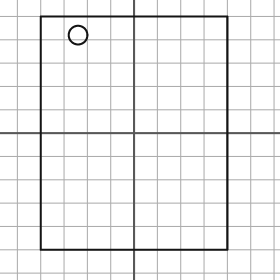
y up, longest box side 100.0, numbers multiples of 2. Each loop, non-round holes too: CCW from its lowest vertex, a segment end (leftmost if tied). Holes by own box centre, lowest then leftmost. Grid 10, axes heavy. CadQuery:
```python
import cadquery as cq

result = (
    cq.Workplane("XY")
    .moveTo(-40.0, -50.0)
    .lineTo(40.0, -50.0)
    .lineTo(40.0, 50.0)
    .lineTo(-40.0, 50.0)
    .close()
    .moveTo(-24.0, 42.0)
    .circle(4.0)
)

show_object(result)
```